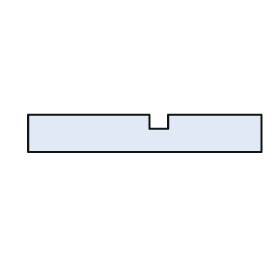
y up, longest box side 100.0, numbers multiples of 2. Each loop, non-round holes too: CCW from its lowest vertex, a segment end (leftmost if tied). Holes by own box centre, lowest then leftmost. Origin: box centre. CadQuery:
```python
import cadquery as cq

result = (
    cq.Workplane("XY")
    .moveTo(-50.0, -8.0)
    .lineTo(50.0, -8.0)
    .lineTo(50.0, 8.0)
    .lineTo(10.0, 8.0)
    .lineTo(10.0, 2.0)
    .lineTo(2.0, 2.0)
    .lineTo(2.0, 8.0)
    .lineTo(-50.0, 8.0)
    .close()
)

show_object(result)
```